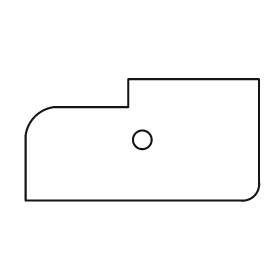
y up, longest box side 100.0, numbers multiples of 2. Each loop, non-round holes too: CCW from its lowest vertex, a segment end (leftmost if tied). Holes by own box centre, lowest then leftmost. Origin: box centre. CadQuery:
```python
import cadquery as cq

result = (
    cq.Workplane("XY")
    .moveTo(-50.0, -26.0)
    .lineTo(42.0, -26.0)
    .threePointArc((48.0, -24.0), (50.0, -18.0))
    .lineTo(50.0, 26.0)
    .lineTo(-6.0, 26.0)
    .lineTo(-6.0, 14.0)
    .lineTo(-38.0, 14.0)
    .threePointArc((-46.0, 10.0), (-50.0, 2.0))
    .close()
    .moveTo(0.0, 0.0)
    .circle(4.0)
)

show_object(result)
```